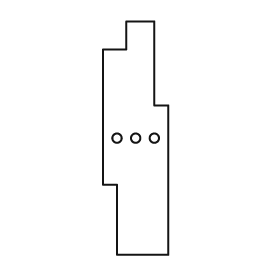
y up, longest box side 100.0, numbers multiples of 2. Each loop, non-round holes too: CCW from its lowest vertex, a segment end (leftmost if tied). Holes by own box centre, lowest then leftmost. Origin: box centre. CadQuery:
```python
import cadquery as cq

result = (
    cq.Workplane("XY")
    .moveTo(-8.0, -50.0)
    .lineTo(14.0, -50.0)
    .lineTo(14.0, 14.0)
    .lineTo(8.0, 14.0)
    .lineTo(8.0, 50.0)
    .lineTo(-4.0, 50.0)
    .lineTo(-4.0, 38.0)
    .lineTo(-14.0, 38.0)
    .lineTo(-14.0, -20.0)
    .lineTo(-8.0, -20.0)
    .close()
    .moveTo(-8.0, 0.0)
    .circle(2.0)
    .moveTo(0.0, 0.0)
    .circle(2.0)
    .moveTo(8.0, 0.0)
    .circle(2.0)
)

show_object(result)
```